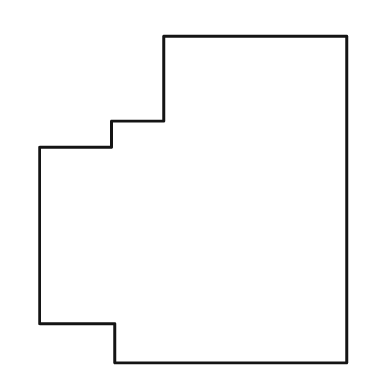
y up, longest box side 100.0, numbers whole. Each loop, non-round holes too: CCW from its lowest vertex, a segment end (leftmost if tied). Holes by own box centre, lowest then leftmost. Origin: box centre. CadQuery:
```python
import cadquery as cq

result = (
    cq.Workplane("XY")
    .moveTo(-24.0, -50.0)
    .lineTo(47.0, -50.0)
    .lineTo(47.0, 50.0)
    .lineTo(-9.0, 50.0)
    .lineTo(-9.0, 24.0)
    .lineTo(-25.0, 24.0)
    .lineTo(-25.0, 16.0)
    .lineTo(-47.0, 16.0)
    .lineTo(-47.0, -38.0)
    .lineTo(-24.0, -38.0)
    .close()
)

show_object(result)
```